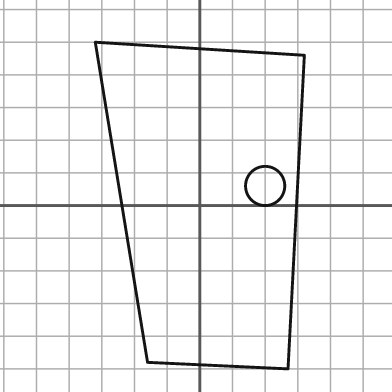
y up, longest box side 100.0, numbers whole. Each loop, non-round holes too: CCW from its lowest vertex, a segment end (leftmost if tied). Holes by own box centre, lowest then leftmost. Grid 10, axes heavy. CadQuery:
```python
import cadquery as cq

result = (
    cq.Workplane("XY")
    .moveTo(27.0, -50.0)
    .lineTo(32.0, 46.0)
    .lineTo(-32.0, 50.0)
    .lineTo(-16.0, -48.0)
    .close()
    .moveTo(20.0, 6.0)
    .circle(6.0)
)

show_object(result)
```